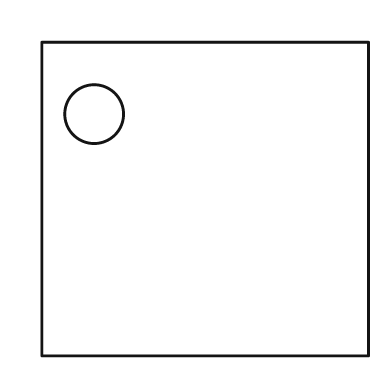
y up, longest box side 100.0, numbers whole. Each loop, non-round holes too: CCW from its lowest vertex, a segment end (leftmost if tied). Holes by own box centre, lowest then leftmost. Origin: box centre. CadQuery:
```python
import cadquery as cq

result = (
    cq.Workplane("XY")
    .moveTo(-50.0, -48.0)
    .lineTo(50.0, -48.0)
    .lineTo(50.0, 48.0)
    .lineTo(-50.0, 48.0)
    .close()
    .moveTo(-34.0, 26.0)
    .circle(9.0)
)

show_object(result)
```